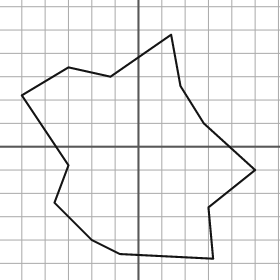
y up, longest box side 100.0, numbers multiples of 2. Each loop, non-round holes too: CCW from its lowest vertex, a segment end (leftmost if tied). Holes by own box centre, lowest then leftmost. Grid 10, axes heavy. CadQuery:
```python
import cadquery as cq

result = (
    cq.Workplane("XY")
    .moveTo(32.0, -48.0)
    .lineTo(30.0, -26.0)
    .lineTo(50.0, -10.0)
    .lineTo(28.0, 10.0)
    .lineTo(18.0, 26.0)
    .lineTo(14.0, 48.0)
    .lineTo(-12.0, 30.0)
    .lineTo(-30.0, 34.0)
    .lineTo(-50.0, 22.0)
    .lineTo(-30.0, -8.0)
    .lineTo(-36.0, -24.0)
    .lineTo(-20.0, -40.0)
    .lineTo(-8.0, -46.0)
    .close()
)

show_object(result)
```